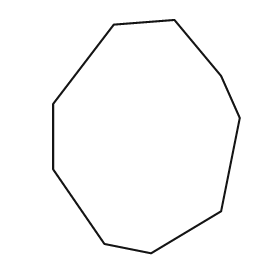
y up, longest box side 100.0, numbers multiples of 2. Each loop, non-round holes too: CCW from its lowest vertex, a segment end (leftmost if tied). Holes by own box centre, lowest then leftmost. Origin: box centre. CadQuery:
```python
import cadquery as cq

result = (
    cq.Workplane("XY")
    .moveTo(2.0, -50.0)
    .lineTo(32.0, -32.0)
    .lineTo(40.0, 8.0)
    .lineTo(32.0, 26.0)
    .lineTo(12.0, 50.0)
    .lineTo(-14.0, 48.0)
    .lineTo(-40.0, 14.0)
    .lineTo(-40.0, -14.0)
    .lineTo(-18.0, -46.0)
    .close()
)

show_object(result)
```